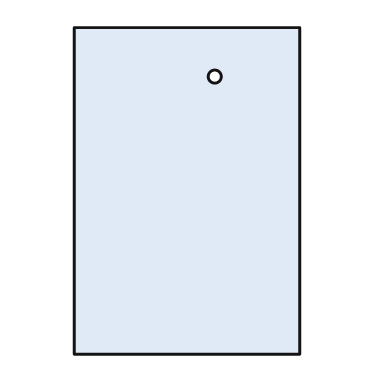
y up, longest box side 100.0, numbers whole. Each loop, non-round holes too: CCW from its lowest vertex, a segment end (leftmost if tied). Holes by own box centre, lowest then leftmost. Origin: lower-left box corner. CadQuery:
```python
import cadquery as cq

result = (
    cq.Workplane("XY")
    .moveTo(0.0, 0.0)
    .lineTo(69.0, 0.0)
    .lineTo(69.0, 100.0)
    .lineTo(0.0, 100.0)
    .close()
    .moveTo(43.0, 85.0)
    .circle(2.0)
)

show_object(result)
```